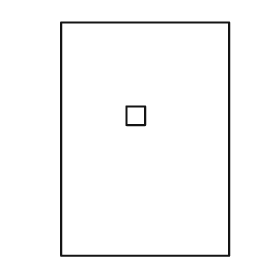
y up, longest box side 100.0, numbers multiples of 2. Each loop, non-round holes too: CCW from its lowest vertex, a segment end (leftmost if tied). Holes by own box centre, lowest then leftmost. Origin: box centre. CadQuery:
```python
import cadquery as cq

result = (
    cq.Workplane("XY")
    .moveTo(-36.0, -50.0)
    .lineTo(36.0, -50.0)
    .lineTo(36.0, 50.0)
    .lineTo(-36.0, 50.0)
    .close()
    .moveTo(-8.0, 6.0)
    .lineTo(0.0, 6.0)
    .lineTo(0.0, 14.0)
    .lineTo(-8.0, 14.0)
    .close()
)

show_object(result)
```